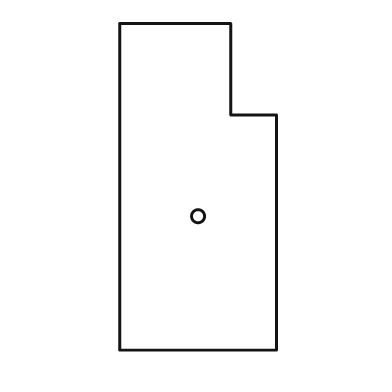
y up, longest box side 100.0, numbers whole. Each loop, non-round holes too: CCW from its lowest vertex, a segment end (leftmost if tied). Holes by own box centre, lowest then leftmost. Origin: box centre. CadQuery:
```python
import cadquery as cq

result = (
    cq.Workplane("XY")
    .moveTo(-24.0, -50.0)
    .lineTo(24.0, -50.0)
    .lineTo(24.0, 22.0)
    .lineTo(10.0, 22.0)
    .lineTo(10.0, 50.0)
    .lineTo(-24.0, 50.0)
    .close()
    .moveTo(0.0, -9.0)
    .circle(2.0)
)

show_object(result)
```